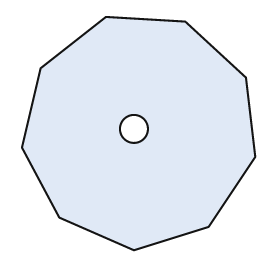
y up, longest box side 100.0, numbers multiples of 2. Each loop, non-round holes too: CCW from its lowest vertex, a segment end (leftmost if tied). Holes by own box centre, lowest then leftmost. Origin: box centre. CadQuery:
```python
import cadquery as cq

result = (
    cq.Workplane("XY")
    .moveTo(-2.0, -50.0)
    .lineTo(30.0, -40.0)
    .lineTo(50.0, -10.0)
    .lineTo(46.0, 24.0)
    .lineTo(20.0, 48.0)
    .lineTo(-14.0, 50.0)
    .lineTo(-42.0, 28.0)
    .lineTo(-50.0, -6.0)
    .lineTo(-34.0, -36.0)
    .close()
    .moveTo(-2.0, 2.0)
    .circle(6.0)
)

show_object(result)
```